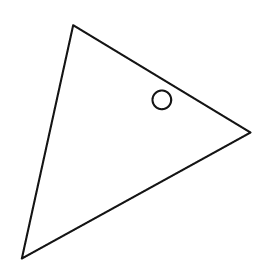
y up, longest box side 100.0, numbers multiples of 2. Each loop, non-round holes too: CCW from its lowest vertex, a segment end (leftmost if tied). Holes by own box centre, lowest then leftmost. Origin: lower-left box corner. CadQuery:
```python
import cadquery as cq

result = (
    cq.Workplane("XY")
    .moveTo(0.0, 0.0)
    .lineTo(98.0, 54.0)
    .lineTo(22.0, 100.0)
    .close()
    .moveTo(60.0, 68.0)
    .circle(4.0)
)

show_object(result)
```